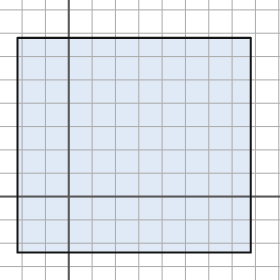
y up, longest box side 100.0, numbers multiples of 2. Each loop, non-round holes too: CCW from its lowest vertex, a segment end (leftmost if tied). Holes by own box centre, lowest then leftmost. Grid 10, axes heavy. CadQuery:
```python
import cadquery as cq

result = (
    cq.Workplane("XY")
    .moveTo(-22.0, -24.0)
    .lineTo(78.0, -24.0)
    .lineTo(78.0, 68.0)
    .lineTo(-22.0, 68.0)
    .close()
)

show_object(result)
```